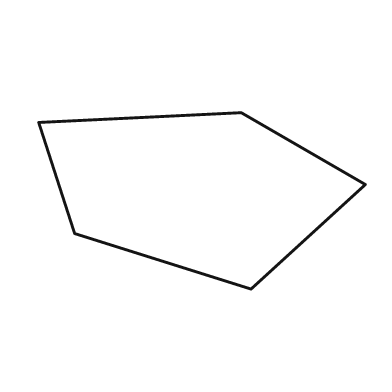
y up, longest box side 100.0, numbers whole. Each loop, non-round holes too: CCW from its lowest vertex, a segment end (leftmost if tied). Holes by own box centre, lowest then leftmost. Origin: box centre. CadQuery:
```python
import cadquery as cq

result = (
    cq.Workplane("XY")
    .moveTo(15.0, -27.0)
    .lineTo(50.0, 5.0)
    .lineTo(12.0, 27.0)
    .lineTo(-50.0, 24.0)
    .lineTo(-39.0, -10.0)
    .close()
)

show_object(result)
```